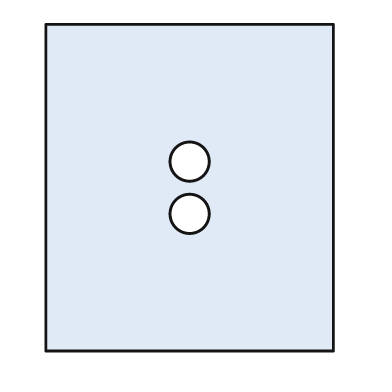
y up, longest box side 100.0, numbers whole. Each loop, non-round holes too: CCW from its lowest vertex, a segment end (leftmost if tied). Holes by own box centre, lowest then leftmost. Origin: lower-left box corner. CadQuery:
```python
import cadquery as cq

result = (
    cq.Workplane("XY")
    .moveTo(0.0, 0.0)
    .lineTo(88.0, 0.0)
    .lineTo(88.0, 100.0)
    .lineTo(0.0, 100.0)
    .close()
    .moveTo(44.0, 42.0)
    .circle(6.0)
    .moveTo(44.0, 58.0)
    .circle(6.0)
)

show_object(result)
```